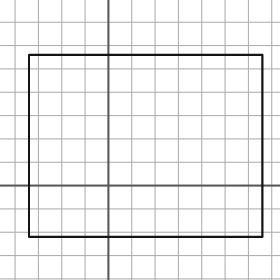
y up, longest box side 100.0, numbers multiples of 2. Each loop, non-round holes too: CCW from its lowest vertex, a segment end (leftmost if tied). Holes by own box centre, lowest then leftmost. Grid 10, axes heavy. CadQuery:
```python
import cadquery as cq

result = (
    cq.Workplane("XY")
    .moveTo(-34.0, -22.0)
    .lineTo(66.0, -22.0)
    .lineTo(66.0, 56.0)
    .lineTo(-34.0, 56.0)
    .close()
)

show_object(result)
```